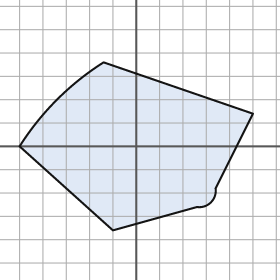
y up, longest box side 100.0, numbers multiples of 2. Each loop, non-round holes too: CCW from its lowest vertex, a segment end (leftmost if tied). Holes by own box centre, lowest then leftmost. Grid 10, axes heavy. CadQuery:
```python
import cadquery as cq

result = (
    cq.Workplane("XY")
    .moveTo(-10.0, -36.0)
    .lineTo(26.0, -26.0)
    .threePointArc((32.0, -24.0), (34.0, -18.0))
    .lineTo(50.0, 14.0)
    .lineTo(-14.0, 36.0)
    .threePointArc((-34.0, 20.0), (-50.0, 0.0))
    .close()
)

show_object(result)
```